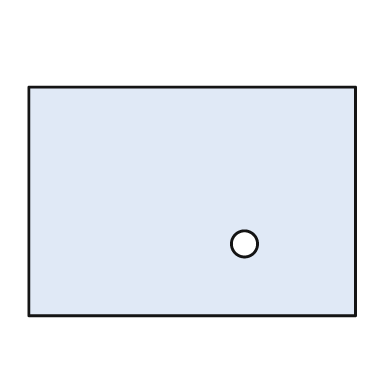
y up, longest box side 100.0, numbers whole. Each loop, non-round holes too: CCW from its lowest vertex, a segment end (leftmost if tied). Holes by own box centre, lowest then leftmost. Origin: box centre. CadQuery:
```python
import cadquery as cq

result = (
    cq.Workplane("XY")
    .moveTo(-50.0, -35.0)
    .lineTo(50.0, -35.0)
    .lineTo(50.0, 35.0)
    .lineTo(-50.0, 35.0)
    .close()
    .moveTo(16.0, -13.0)
    .circle(4.0)
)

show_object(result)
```